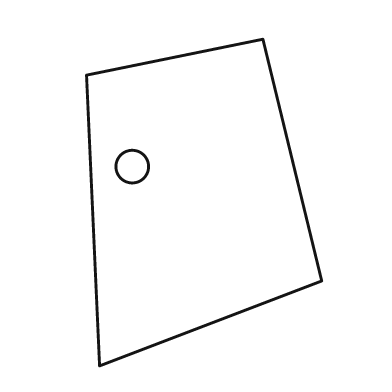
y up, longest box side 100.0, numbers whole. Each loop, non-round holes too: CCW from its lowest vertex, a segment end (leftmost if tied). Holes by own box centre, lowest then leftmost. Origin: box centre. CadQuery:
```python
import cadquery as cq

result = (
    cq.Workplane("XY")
    .moveTo(-32.0, -50.0)
    .lineTo(36.0, -24.0)
    .lineTo(18.0, 50.0)
    .lineTo(-36.0, 39.0)
    .close()
    .moveTo(-22.0, 11.0)
    .circle(5.0)
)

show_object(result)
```